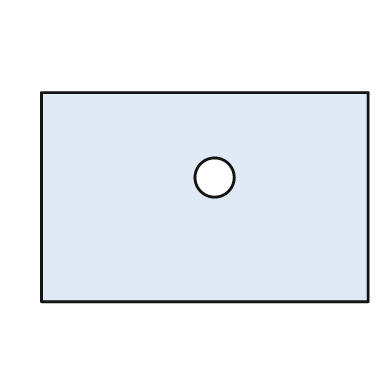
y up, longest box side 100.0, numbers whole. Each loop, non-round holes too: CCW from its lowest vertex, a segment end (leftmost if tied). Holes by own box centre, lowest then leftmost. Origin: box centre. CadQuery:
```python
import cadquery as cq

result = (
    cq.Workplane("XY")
    .moveTo(-50.0, -32.0)
    .lineTo(50.0, -32.0)
    .lineTo(50.0, 32.0)
    .lineTo(-50.0, 32.0)
    .close()
    .moveTo(3.0, 6.0)
    .circle(6.0)
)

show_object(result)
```